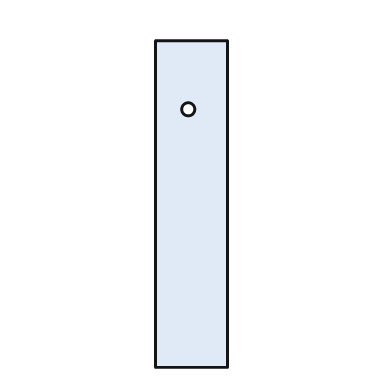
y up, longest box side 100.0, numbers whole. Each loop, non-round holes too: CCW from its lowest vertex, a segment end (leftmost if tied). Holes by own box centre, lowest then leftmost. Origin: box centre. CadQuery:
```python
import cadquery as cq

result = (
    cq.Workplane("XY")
    .moveTo(-11.0, -50.0)
    .lineTo(11.0, -50.0)
    .lineTo(11.0, 50.0)
    .lineTo(-11.0, 50.0)
    .close()
    .moveTo(-1.0, 29.0)
    .circle(2.0)
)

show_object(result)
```